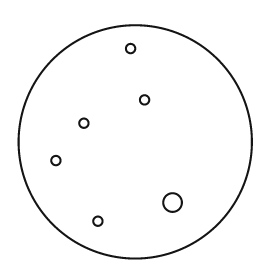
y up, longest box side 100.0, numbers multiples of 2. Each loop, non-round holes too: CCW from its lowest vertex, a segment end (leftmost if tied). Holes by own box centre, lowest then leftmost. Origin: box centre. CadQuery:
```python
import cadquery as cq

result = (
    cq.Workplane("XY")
    .moveTo(0.0, 0.0)
    .circle(50.0)
    .moveTo(-16.0, -34.0)
    .circle(2.0)
    .moveTo(16.0, -26.0)
    .circle(4.0)
    .moveTo(-34.0, -8.0)
    .circle(2.0)
    .moveTo(-22.0, 8.0)
    .circle(2.0)
    .moveTo(4.0, 18.0)
    .circle(2.0)
    .moveTo(-2.0, 40.0)
    .circle(2.0)
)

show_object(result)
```